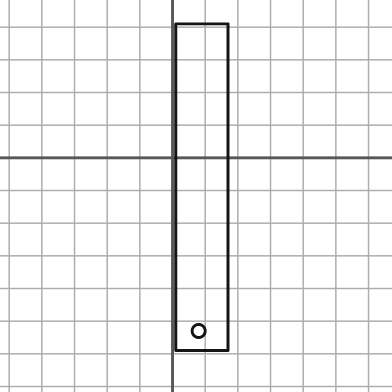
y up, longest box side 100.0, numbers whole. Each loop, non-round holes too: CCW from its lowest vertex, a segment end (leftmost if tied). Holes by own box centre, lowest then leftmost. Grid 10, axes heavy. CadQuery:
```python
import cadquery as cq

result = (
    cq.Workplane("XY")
    .moveTo(1.0, -59.0)
    .lineTo(17.0, -59.0)
    .lineTo(17.0, 41.0)
    .lineTo(1.0, 41.0)
    .close()
    .moveTo(8.0, -53.0)
    .circle(2.0)
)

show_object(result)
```